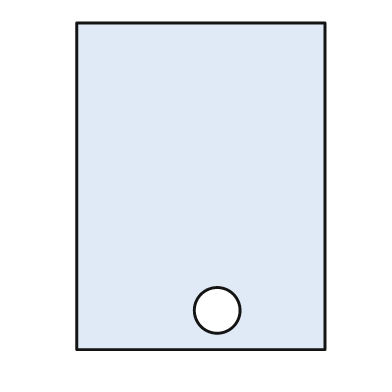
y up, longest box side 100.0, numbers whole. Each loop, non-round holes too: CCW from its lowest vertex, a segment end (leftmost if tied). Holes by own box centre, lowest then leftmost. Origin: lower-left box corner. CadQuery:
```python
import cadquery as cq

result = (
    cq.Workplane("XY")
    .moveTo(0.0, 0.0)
    .lineTo(76.0, 0.0)
    .lineTo(76.0, 100.0)
    .lineTo(0.0, 100.0)
    .close()
    .moveTo(43.0, 12.0)
    .circle(7.0)
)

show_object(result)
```